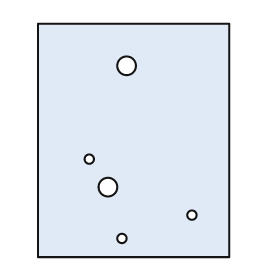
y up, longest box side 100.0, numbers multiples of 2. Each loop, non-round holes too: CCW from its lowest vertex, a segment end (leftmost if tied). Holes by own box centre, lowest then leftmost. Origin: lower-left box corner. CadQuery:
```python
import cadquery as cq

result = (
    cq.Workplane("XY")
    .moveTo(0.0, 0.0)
    .lineTo(82.0, 0.0)
    .lineTo(82.0, 100.0)
    .lineTo(0.0, 100.0)
    .close()
    .moveTo(36.0, 8.0)
    .circle(2.0)
    .moveTo(66.0, 18.0)
    .circle(2.0)
    .moveTo(30.0, 30.0)
    .circle(4.0)
    .moveTo(22.0, 42.0)
    .circle(2.0)
    .moveTo(38.0, 82.0)
    .circle(4.0)
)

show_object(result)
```